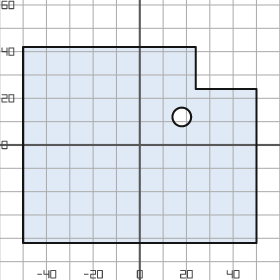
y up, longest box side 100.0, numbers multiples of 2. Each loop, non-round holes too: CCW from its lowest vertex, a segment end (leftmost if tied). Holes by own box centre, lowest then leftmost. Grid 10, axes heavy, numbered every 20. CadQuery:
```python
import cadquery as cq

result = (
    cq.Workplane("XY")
    .moveTo(-50.0, -42.0)
    .lineTo(50.0, -42.0)
    .lineTo(50.0, 24.0)
    .lineTo(24.0, 24.0)
    .lineTo(24.0, 42.0)
    .lineTo(-50.0, 42.0)
    .close()
    .moveTo(18.0, 12.0)
    .circle(4.0)
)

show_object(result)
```